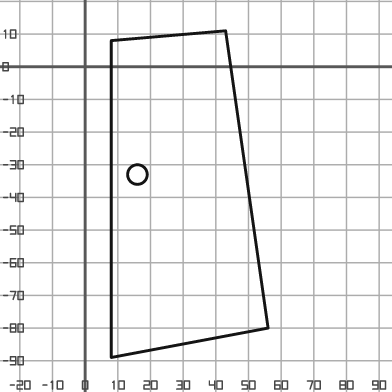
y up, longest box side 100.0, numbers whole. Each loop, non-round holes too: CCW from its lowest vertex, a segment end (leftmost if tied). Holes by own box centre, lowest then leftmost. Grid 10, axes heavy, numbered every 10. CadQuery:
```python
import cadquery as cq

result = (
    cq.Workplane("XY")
    .moveTo(8.0, -89.0)
    .lineTo(56.0, -80.0)
    .lineTo(43.0, 11.0)
    .lineTo(8.0, 8.0)
    .close()
    .moveTo(16.0, -33.0)
    .circle(3.0)
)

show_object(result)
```